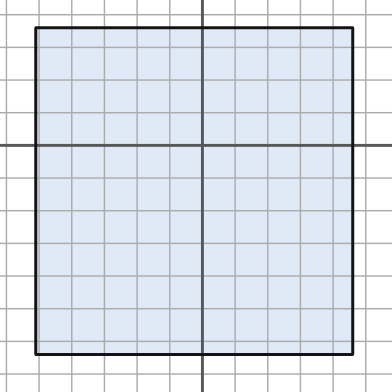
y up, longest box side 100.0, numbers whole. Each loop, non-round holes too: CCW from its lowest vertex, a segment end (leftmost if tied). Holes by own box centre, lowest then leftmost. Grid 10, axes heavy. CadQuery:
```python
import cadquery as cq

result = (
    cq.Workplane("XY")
    .moveTo(-51.0, -64.0)
    .lineTo(46.0, -64.0)
    .lineTo(46.0, 36.0)
    .lineTo(-51.0, 36.0)
    .close()
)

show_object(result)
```